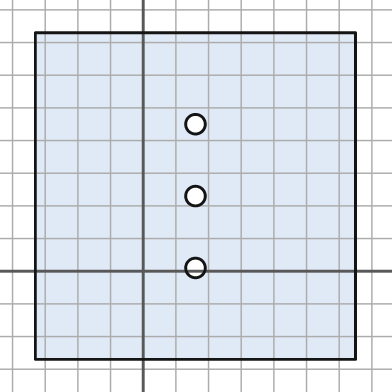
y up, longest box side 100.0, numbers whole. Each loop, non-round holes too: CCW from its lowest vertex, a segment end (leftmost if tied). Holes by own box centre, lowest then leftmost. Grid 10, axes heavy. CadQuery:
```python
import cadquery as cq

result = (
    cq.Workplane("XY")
    .moveTo(-33.0, -27.0)
    .lineTo(65.0, -27.0)
    .lineTo(65.0, 73.0)
    .lineTo(-33.0, 73.0)
    .close()
    .moveTo(16.0, 1.0)
    .circle(3.0)
    .moveTo(16.0, 23.0)
    .circle(3.0)
    .moveTo(16.0, 45.0)
    .circle(3.0)
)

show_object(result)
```